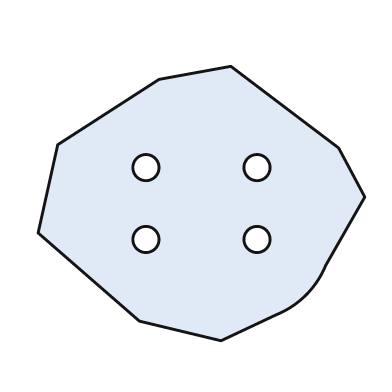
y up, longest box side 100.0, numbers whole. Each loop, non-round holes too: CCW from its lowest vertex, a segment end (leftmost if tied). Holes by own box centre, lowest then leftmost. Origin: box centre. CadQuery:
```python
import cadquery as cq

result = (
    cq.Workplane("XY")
    .moveTo(6.0, -42.0)
    .lineTo(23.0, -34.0)
    .threePointArc((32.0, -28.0), (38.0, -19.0))
    .lineTo(50.0, 2.0)
    .lineTo(42.0, 17.0)
    .lineTo(9.0, 42.0)
    .lineTo(-13.0, 38.0)
    .lineTo(-44.0, 18.0)
    .lineTo(-50.0, -9.0)
    .lineTo(-19.0, -36.0)
    .close()
    .moveTo(-17.0, -11.0)
    .circle(4.0)
    .moveTo(17.0, -11.0)
    .circle(4.0)
    .moveTo(-17.0, 11.0)
    .circle(4.0)
    .moveTo(17.0, 11.0)
    .circle(4.0)
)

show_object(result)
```